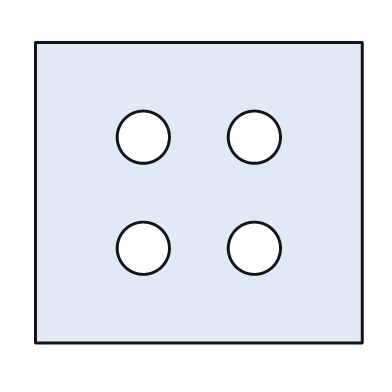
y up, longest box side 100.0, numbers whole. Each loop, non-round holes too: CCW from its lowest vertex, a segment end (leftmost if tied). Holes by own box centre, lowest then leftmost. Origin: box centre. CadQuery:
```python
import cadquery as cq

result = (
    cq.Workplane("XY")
    .moveTo(-50.0, -46.0)
    .lineTo(50.0, -46.0)
    .lineTo(50.0, 46.0)
    .lineTo(-50.0, 46.0)
    .close()
    .moveTo(-17.0, -17.0)
    .circle(8.0)
    .moveTo(17.0, -17.0)
    .circle(8.0)
    .moveTo(-17.0, 17.0)
    .circle(8.0)
    .moveTo(17.0, 17.0)
    .circle(8.0)
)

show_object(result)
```